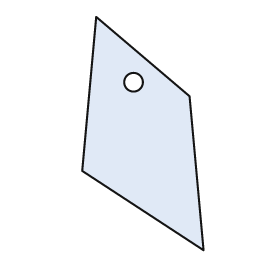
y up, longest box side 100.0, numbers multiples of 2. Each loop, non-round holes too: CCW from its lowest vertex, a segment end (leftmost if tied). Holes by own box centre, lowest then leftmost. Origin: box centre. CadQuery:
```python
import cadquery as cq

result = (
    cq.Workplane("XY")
    .moveTo(26.0, -50.0)
    .lineTo(20.0, 16.0)
    .lineTo(-20.0, 50.0)
    .lineTo(-26.0, -16.0)
    .close()
    .moveTo(-4.0, 22.0)
    .circle(4.0)
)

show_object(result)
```